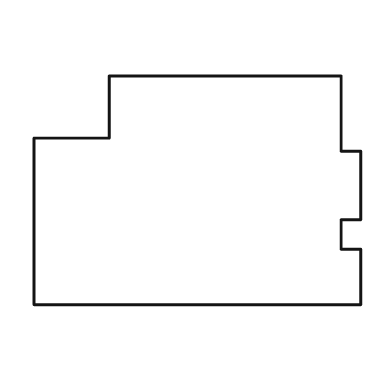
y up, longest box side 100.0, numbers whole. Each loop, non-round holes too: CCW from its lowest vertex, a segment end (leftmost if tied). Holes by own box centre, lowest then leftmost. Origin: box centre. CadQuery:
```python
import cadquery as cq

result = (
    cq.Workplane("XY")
    .moveTo(-50.0, -35.0)
    .lineTo(50.0, -35.0)
    .lineTo(50.0, -18.0)
    .lineTo(44.0, -18.0)
    .lineTo(44.0, -9.0)
    .lineTo(50.0, -9.0)
    .lineTo(50.0, 12.0)
    .lineTo(44.0, 12.0)
    .lineTo(44.0, 35.0)
    .lineTo(-27.0, 35.0)
    .lineTo(-27.0, 16.0)
    .lineTo(-50.0, 16.0)
    .close()
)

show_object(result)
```